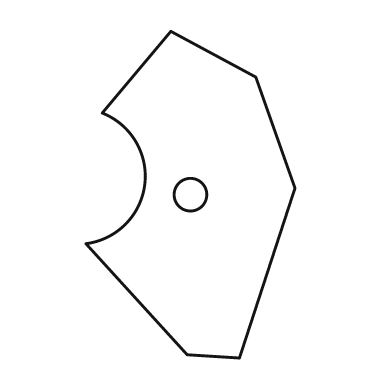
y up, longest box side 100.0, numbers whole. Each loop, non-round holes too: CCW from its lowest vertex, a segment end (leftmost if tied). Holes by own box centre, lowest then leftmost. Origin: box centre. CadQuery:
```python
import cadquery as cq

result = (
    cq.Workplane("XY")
    .moveTo(15.0, -50.0)
    .lineTo(32.0, 2.0)
    .lineTo(20.0, 36.0)
    .lineTo(-6.0, 50.0)
    .lineTo(-27.0, 25.0)
    .threePointArc((-14.0, 3.0), (-32.0, -15.0))
    .lineTo(-1.0, -49.0)
    .close()
    .moveTo(0.0, 0.0)
    .circle(5.0)
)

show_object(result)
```